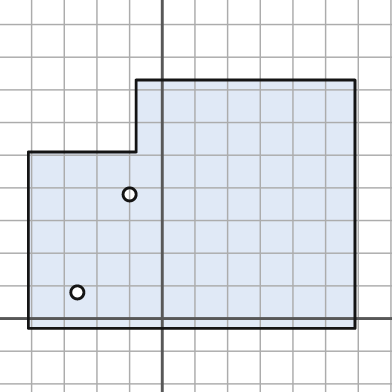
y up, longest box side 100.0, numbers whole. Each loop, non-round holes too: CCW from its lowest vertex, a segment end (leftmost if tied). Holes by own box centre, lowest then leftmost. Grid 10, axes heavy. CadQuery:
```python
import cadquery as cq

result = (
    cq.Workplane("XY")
    .moveTo(-41.0, -3.0)
    .lineTo(59.0, -3.0)
    .lineTo(59.0, 73.0)
    .lineTo(-8.0, 73.0)
    .lineTo(-8.0, 51.0)
    .lineTo(-41.0, 51.0)
    .close()
    .moveTo(-26.0, 8.0)
    .circle(2.0)
    .moveTo(-10.0, 38.0)
    .circle(2.0)
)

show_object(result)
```